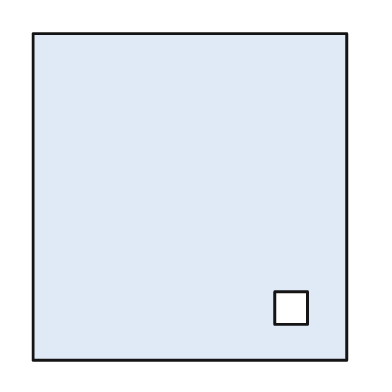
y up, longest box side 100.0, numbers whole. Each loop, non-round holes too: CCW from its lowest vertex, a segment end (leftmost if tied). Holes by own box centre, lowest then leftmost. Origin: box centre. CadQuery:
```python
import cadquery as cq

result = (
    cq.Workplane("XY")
    .moveTo(-48.0, -50.0)
    .lineTo(48.0, -50.0)
    .lineTo(48.0, 50.0)
    .lineTo(-48.0, 50.0)
    .close()
    .moveTo(26.0, -39.0)
    .lineTo(36.0, -39.0)
    .lineTo(36.0, -29.0)
    .lineTo(26.0, -29.0)
    .close()
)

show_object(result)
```